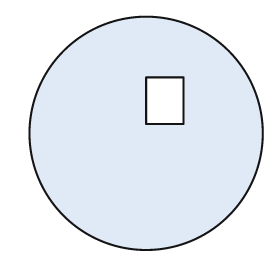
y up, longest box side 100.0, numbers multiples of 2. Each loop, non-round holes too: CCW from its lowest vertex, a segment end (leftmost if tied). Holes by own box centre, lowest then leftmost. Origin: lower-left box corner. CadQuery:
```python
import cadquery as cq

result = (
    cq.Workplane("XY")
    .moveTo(50.0, 50.0)
    .circle(50.0)
    .moveTo(50.0, 54.0)
    .lineTo(66.0, 54.0)
    .lineTo(66.0, 74.0)
    .lineTo(50.0, 74.0)
    .close()
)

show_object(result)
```